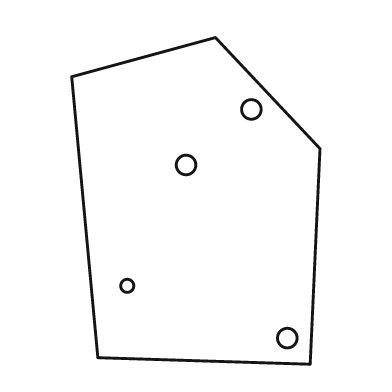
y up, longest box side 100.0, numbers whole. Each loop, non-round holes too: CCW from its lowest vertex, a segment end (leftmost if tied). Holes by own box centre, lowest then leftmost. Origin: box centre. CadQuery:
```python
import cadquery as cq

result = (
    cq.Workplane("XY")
    .moveTo(35.0, -50.0)
    .lineTo(38.0, 16.0)
    .lineTo(6.0, 50.0)
    .lineTo(-38.0, 38.0)
    .lineTo(-30.0, -48.0)
    .close()
    .moveTo(28.0, -42.0)
    .circle(3.0)
    .moveTo(-21.0, -26.0)
    .circle(2.0)
    .moveTo(-3.0, 11.0)
    .circle(3.0)
    .moveTo(17.0, 28.0)
    .circle(3.0)
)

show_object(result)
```